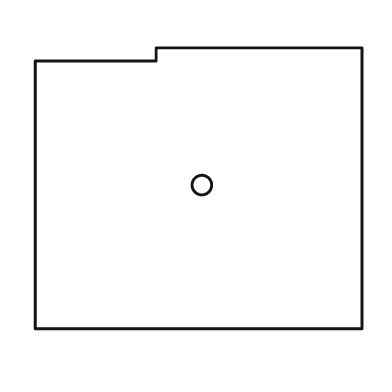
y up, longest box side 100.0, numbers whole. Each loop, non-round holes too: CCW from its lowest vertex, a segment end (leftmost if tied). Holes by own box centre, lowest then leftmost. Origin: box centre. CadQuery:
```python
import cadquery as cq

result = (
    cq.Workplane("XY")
    .moveTo(-50.0, -43.0)
    .lineTo(50.0, -43.0)
    .lineTo(50.0, 43.0)
    .lineTo(-13.0, 43.0)
    .lineTo(-13.0, 39.0)
    .lineTo(-50.0, 39.0)
    .close()
    .moveTo(1.0, 1.0)
    .circle(3.0)
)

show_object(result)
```